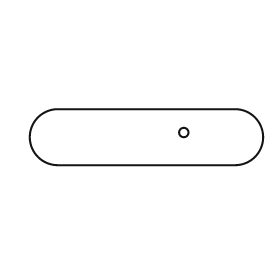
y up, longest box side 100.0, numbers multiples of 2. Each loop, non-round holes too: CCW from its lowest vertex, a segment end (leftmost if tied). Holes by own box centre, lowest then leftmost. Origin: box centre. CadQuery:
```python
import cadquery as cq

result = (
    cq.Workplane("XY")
    .moveTo(-38.0, -12.0)
    .lineTo(38.0, -12.0)
    .threePointArc((50.0, 0.0), (38.0, 12.0))
    .lineTo(-38.0, 12.0)
    .threePointArc((-50.0, 0.0), (-38.0, -12.0))
    .close()
    .moveTo(16.0, 2.0)
    .circle(2.0)
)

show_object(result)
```